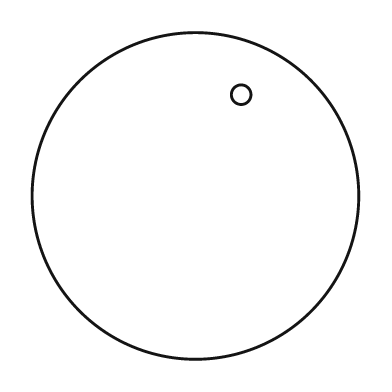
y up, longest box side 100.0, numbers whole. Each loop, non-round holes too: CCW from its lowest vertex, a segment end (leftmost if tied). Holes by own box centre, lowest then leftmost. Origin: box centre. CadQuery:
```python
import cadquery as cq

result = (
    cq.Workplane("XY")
    .moveTo(0.0, 0.0)
    .circle(50.0)
    .moveTo(14.0, 31.0)
    .circle(3.0)
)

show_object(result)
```